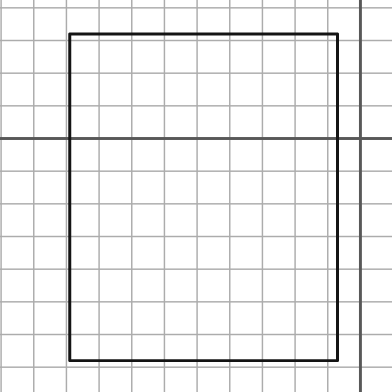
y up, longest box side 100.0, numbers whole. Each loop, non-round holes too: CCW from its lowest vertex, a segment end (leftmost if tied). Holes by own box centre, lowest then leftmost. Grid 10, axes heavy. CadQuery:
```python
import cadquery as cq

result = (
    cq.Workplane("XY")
    .moveTo(-89.0, -68.0)
    .lineTo(-7.0, -68.0)
    .lineTo(-7.0, 32.0)
    .lineTo(-89.0, 32.0)
    .close()
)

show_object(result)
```